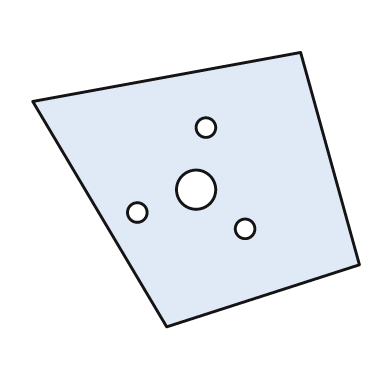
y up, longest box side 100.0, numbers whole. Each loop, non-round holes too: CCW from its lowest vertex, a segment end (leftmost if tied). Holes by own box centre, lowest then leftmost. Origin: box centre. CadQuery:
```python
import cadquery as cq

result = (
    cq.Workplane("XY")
    .moveTo(-9.0, -42.0)
    .lineTo(50.0, -23.0)
    .lineTo(32.0, 42.0)
    .lineTo(-50.0, 27.0)
    .close()
    .moveTo(15.0, -12.0)
    .circle(3.0)
    .moveTo(-18.0, -7.0)
    .circle(3.0)
    .moveTo(0.0, 0.0)
    .circle(6.0)
    .moveTo(3.0, 19.0)
    .circle(3.0)
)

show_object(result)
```